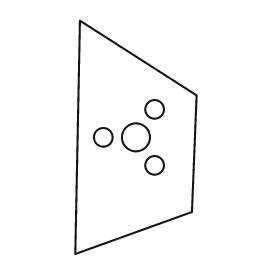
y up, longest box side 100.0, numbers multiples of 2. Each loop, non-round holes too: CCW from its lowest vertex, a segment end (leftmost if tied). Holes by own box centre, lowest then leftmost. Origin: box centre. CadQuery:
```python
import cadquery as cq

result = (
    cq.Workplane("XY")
    .moveTo(-26.0, -50.0)
    .lineTo(24.0, -32.0)
    .lineTo(26.0, 18.0)
    .lineTo(-24.0, 50.0)
    .close()
    .moveTo(8.0, -12.0)
    .circle(4.0)
    .moveTo(-14.0, 0.0)
    .circle(4.0)
    .moveTo(0.0, 0.0)
    .circle(6.0)
    .moveTo(8.0, 12.0)
    .circle(4.0)
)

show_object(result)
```